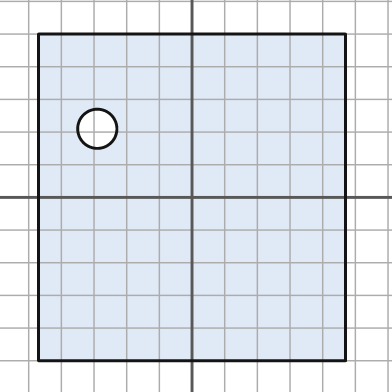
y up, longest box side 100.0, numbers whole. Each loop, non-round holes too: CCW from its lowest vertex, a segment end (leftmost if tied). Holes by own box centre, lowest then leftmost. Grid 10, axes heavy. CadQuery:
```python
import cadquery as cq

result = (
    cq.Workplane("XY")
    .moveTo(-47.0, -50.0)
    .lineTo(47.0, -50.0)
    .lineTo(47.0, 50.0)
    .lineTo(-47.0, 50.0)
    .close()
    .moveTo(-29.0, 21.0)
    .circle(6.0)
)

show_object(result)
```